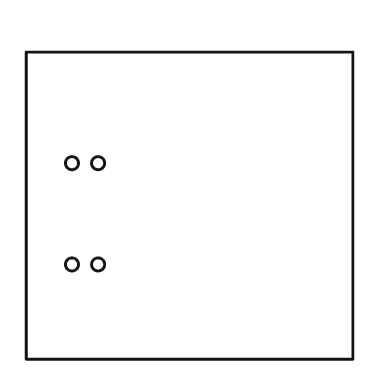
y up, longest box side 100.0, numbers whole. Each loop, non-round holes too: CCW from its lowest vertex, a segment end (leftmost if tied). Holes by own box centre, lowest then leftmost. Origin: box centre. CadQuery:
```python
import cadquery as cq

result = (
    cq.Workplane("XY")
    .moveTo(-50.0, -47.0)
    .lineTo(50.0, -47.0)
    .lineTo(50.0, 47.0)
    .lineTo(-50.0, 47.0)
    .close()
    .moveTo(-36.0, -18.0)
    .circle(2.0)
    .moveTo(-28.0, -18.0)
    .circle(2.0)
    .moveTo(-36.0, 13.0)
    .circle(2.0)
    .moveTo(-28.0, 13.0)
    .circle(2.0)
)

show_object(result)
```